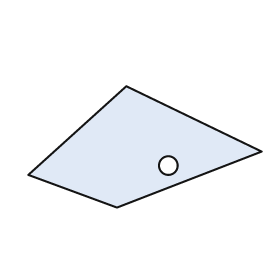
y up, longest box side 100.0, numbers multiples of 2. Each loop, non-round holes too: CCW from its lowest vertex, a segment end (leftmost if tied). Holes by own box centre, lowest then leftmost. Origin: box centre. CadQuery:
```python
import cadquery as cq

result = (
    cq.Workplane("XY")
    .moveTo(-12.0, -26.0)
    .lineTo(50.0, -2.0)
    .lineTo(-8.0, 26.0)
    .lineTo(-50.0, -12.0)
    .close()
    .moveTo(10.0, -8.0)
    .circle(4.0)
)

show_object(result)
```